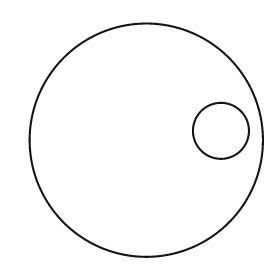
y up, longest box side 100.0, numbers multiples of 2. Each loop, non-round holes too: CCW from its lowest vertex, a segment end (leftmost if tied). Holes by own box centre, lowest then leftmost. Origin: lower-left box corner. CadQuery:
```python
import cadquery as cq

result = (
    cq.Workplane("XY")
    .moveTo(50.0, 50.0)
    .circle(50.0)
    .moveTo(82.0, 54.0)
    .circle(12.0)
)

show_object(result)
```